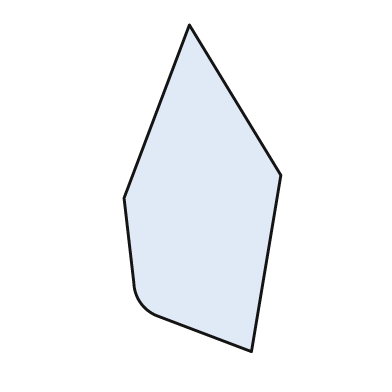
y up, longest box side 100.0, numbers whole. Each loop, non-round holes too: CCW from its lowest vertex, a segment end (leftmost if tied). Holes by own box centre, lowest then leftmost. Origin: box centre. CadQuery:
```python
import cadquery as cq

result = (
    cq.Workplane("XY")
    .moveTo(15.0, -50.0)
    .lineTo(24.0, 4.0)
    .lineTo(-4.0, 50.0)
    .lineTo(-24.0, -3.0)
    .lineTo(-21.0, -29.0)
    .threePointArc((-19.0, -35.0), (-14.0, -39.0))
    .close()
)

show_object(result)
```